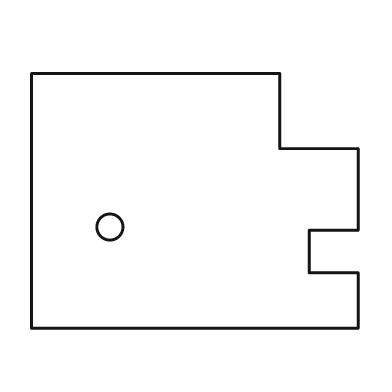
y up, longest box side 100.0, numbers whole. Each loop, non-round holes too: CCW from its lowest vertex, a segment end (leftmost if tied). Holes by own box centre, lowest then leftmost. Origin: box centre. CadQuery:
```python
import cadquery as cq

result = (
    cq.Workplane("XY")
    .moveTo(-50.0, -39.0)
    .lineTo(50.0, -39.0)
    .lineTo(50.0, -22.0)
    .lineTo(35.0, -22.0)
    .lineTo(35.0, -9.0)
    .lineTo(50.0, -9.0)
    .lineTo(50.0, 16.0)
    .lineTo(26.0, 16.0)
    .lineTo(26.0, 39.0)
    .lineTo(-50.0, 39.0)
    .close()
    .moveTo(-26.0, -8.0)
    .circle(4.0)
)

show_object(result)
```